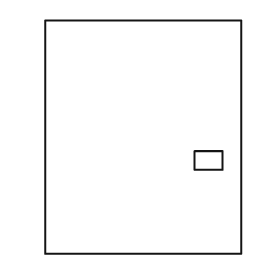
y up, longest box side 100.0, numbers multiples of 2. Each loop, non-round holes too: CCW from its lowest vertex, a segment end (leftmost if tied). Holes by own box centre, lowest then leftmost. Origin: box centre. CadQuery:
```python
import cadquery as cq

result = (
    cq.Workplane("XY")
    .moveTo(-42.0, -50.0)
    .lineTo(42.0, -50.0)
    .lineTo(42.0, 50.0)
    .lineTo(-42.0, 50.0)
    .close()
    .moveTo(22.0, -14.0)
    .lineTo(34.0, -14.0)
    .lineTo(34.0, -6.0)
    .lineTo(22.0, -6.0)
    .close()
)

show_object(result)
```